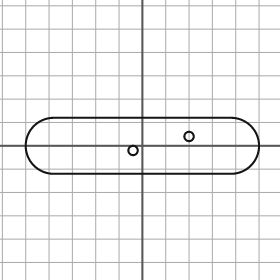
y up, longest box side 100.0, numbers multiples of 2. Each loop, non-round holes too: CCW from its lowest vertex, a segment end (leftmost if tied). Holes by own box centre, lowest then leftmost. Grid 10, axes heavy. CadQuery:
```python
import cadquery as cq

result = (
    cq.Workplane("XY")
    .moveTo(-38.0, -12.0)
    .lineTo(38.0, -12.0)
    .threePointArc((50.0, 0.0), (38.0, 12.0))
    .lineTo(-38.0, 12.0)
    .threePointArc((-50.0, 0.0), (-38.0, -12.0))
    .close()
    .moveTo(-4.0, -2.0)
    .circle(2.0)
    .moveTo(20.0, 4.0)
    .circle(2.0)
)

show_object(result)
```